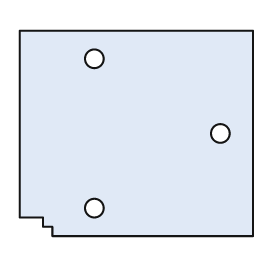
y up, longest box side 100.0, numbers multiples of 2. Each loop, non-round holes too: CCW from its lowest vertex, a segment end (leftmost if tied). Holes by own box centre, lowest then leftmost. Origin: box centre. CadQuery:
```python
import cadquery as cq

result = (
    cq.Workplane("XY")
    .moveTo(-36.0, -44.0)
    .lineTo(50.0, -44.0)
    .lineTo(50.0, 44.0)
    .lineTo(-50.0, 44.0)
    .lineTo(-50.0, -36.0)
    .lineTo(-40.0, -36.0)
    .lineTo(-40.0, -40.0)
    .lineTo(-36.0, -40.0)
    .close()
    .moveTo(-18.0, -32.0)
    .circle(4.0)
    .moveTo(36.0, 0.0)
    .circle(4.0)
    .moveTo(-18.0, 32.0)
    .circle(4.0)
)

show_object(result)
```